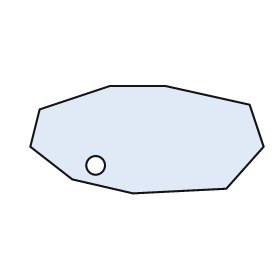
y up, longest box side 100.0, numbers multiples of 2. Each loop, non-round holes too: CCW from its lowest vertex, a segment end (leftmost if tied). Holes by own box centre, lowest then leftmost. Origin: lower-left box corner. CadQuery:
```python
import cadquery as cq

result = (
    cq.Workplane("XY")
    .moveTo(44.0, 0.0)
    .lineTo(84.0, 2.0)
    .lineTo(100.0, 20.0)
    .lineTo(94.0, 38.0)
    .lineTo(58.0, 46.0)
    .lineTo(34.0, 46.0)
    .lineTo(4.0, 36.0)
    .lineTo(0.0, 20.0)
    .lineTo(18.0, 6.0)
    .close()
    .moveTo(28.0, 12.0)
    .circle(4.0)
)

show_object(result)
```